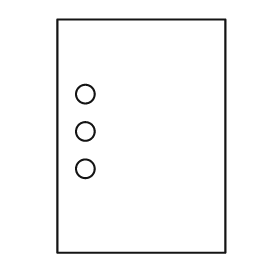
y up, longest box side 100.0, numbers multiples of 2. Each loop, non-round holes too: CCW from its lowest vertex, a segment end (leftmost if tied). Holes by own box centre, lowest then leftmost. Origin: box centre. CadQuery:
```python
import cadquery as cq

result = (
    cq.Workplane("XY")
    .moveTo(-36.0, -50.0)
    .lineTo(36.0, -50.0)
    .lineTo(36.0, 50.0)
    .lineTo(-36.0, 50.0)
    .close()
    .moveTo(-24.0, -14.0)
    .circle(4.0)
    .moveTo(-24.0, 2.0)
    .circle(4.0)
    .moveTo(-24.0, 18.0)
    .circle(4.0)
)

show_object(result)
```